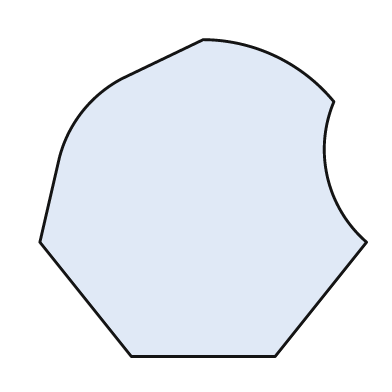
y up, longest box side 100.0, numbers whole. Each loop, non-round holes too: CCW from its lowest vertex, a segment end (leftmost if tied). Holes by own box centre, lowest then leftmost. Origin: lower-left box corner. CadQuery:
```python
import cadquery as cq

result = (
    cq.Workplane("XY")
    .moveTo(28.0, 0.0)
    .lineTo(72.0, 0.0)
    .lineTo(100.0, 35.0)
    .threePointArc((88.0, 55.0), (90.0, 78.0))
    .threePointArc((72.0, 92.0), (50.0, 97.0))
    .lineTo(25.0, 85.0)
    .threePointArc((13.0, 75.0), (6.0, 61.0))
    .lineTo(0.0, 35.0)
    .close()
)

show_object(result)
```